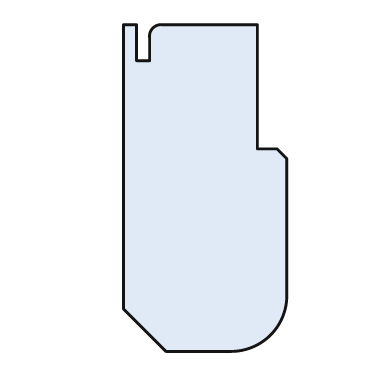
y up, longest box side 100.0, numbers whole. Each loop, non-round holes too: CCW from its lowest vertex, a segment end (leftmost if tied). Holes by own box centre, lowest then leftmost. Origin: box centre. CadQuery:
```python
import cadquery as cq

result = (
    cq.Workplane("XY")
    .moveTo(-12.0, -50.0)
    .lineTo(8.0, -50.0)
    .threePointArc((20.0, -45.0), (25.0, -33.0))
    .lineTo(25.0, 9.0)
    .lineTo(22.0, 12.0)
    .lineTo(16.0, 12.0)
    .lineTo(16.0, 50.0)
    .lineTo(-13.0, 50.0)
    .threePointArc((-16.0, 49.0), (-17.0, 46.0))
    .lineTo(-17.0, 39.0)
    .lineTo(-21.0, 39.0)
    .lineTo(-21.0, 50.0)
    .lineTo(-25.0, 50.0)
    .lineTo(-25.0, -37.0)
    .close()
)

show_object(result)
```